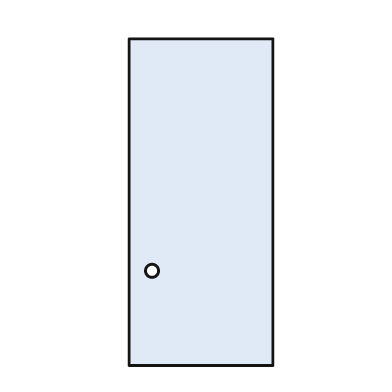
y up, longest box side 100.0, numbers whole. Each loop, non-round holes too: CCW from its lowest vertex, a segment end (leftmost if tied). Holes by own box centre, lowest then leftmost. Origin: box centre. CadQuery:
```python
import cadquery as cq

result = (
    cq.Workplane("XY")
    .moveTo(-22.0, -50.0)
    .lineTo(22.0, -50.0)
    .lineTo(22.0, 50.0)
    .lineTo(-22.0, 50.0)
    .close()
    .moveTo(-15.0, -21.0)
    .circle(2.0)
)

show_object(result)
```